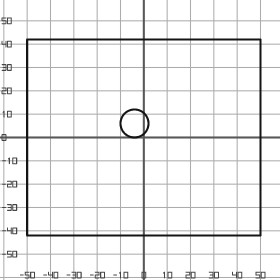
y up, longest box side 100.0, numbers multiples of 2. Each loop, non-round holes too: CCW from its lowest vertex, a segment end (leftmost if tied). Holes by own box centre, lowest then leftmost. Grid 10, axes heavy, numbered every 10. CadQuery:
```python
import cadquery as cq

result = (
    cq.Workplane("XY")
    .moveTo(-50.0, -42.0)
    .lineTo(50.0, -42.0)
    .lineTo(50.0, 42.0)
    .lineTo(-50.0, 42.0)
    .close()
    .moveTo(-4.0, 6.0)
    .circle(6.0)
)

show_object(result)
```